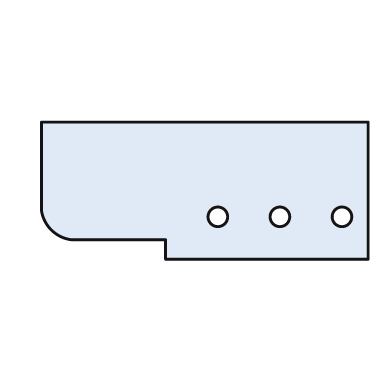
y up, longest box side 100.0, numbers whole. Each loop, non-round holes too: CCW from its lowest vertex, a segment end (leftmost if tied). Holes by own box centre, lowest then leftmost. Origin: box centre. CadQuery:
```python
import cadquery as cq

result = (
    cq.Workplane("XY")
    .moveTo(-12.0, -21.0)
    .lineTo(50.0, -21.0)
    .lineTo(50.0, 21.0)
    .lineTo(-50.0, 21.0)
    .lineTo(-50.0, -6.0)
    .threePointArc((-47.0, -12.0), (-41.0, -15.0))
    .lineTo(-12.0, -15.0)
    .close()
    .moveTo(4.0, -8.0)
    .circle(3.0)
    .moveTo(23.0, -8.0)
    .circle(3.0)
    .moveTo(42.0, -8.0)
    .circle(3.0)
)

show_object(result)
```